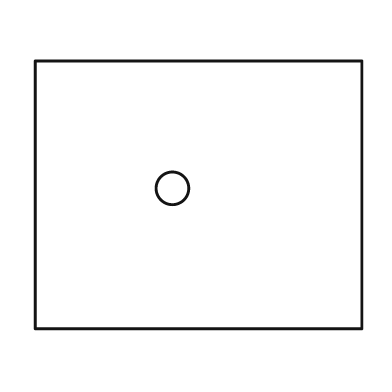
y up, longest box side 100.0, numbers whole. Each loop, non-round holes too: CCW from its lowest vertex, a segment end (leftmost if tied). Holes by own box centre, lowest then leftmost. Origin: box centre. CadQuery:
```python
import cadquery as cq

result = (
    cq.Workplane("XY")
    .moveTo(-50.0, -41.0)
    .lineTo(50.0, -41.0)
    .lineTo(50.0, 41.0)
    .lineTo(-50.0, 41.0)
    .close()
    .moveTo(-8.0, 2.0)
    .circle(5.0)
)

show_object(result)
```